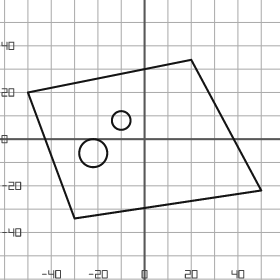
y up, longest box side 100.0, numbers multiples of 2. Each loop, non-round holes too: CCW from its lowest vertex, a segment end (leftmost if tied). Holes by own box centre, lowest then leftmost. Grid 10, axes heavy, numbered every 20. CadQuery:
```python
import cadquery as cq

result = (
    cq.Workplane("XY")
    .moveTo(-30.0, -34.0)
    .lineTo(50.0, -22.0)
    .lineTo(20.0, 34.0)
    .lineTo(-50.0, 20.0)
    .close()
    .moveTo(-22.0, -6.0)
    .circle(6.0)
    .moveTo(-10.0, 8.0)
    .circle(4.0)
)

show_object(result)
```